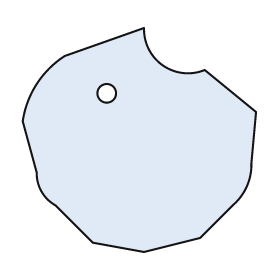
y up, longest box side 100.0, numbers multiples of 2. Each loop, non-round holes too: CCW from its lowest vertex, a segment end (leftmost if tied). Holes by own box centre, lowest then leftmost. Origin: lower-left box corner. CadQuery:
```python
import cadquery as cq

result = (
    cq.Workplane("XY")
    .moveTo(52.0, 0.0)
    .lineTo(76.0, 6.0)
    .lineTo(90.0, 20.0)
    .threePointArc((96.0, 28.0), (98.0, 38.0))
    .lineTo(100.0, 60.0)
    .lineTo(78.0, 78.0)
    .threePointArc((60.0, 80.0), (52.0, 96.0))
    .lineTo(18.0, 84.0)
    .threePointArc((6.0, 72.0), (0.0, 56.0))
    .lineTo(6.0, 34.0)
    .threePointArc((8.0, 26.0), (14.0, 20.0))
    .lineTo(30.0, 4.0)
    .close()
    .moveTo(36.0, 68.0)
    .circle(4.0)
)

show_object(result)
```